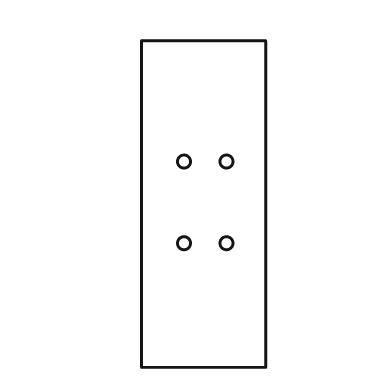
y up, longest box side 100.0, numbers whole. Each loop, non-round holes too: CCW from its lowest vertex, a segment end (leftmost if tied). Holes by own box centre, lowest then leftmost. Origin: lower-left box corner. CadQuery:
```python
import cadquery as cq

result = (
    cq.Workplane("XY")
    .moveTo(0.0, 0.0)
    .lineTo(38.0, 0.0)
    .lineTo(38.0, 100.0)
    .lineTo(0.0, 100.0)
    .close()
    .moveTo(13.0, 38.0)
    .circle(2.0)
    .moveTo(26.0, 38.0)
    .circle(2.0)
    .moveTo(13.0, 63.0)
    .circle(2.0)
    .moveTo(26.0, 63.0)
    .circle(2.0)
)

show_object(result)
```